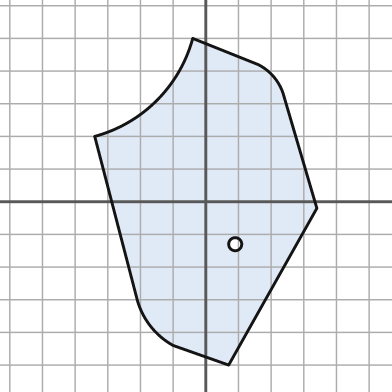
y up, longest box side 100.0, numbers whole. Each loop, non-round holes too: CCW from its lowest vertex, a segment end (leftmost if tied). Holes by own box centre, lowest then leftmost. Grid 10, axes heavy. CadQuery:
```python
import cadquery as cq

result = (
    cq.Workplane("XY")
    .moveTo(7.0, -50.0)
    .lineTo(34.0, -2.0)
    .lineTo(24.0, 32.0)
    .threePointArc((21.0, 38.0), (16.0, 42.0))
    .lineTo(-4.0, 50.0)
    .threePointArc((-15.0, 31.0), (-34.0, 20.0))
    .lineTo(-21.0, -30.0)
    .threePointArc((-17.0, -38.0), (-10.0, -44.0))
    .close()
    .moveTo(9.0, -13.0)
    .circle(2.0)
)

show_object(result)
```